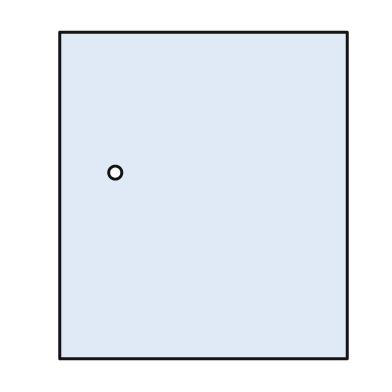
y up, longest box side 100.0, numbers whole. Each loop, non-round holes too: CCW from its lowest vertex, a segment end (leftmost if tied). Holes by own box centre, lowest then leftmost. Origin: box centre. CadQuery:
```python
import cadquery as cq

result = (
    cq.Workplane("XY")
    .moveTo(-44.0, -50.0)
    .lineTo(44.0, -50.0)
    .lineTo(44.0, 50.0)
    .lineTo(-44.0, 50.0)
    .close()
    .moveTo(-27.0, 7.0)
    .circle(2.0)
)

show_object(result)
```